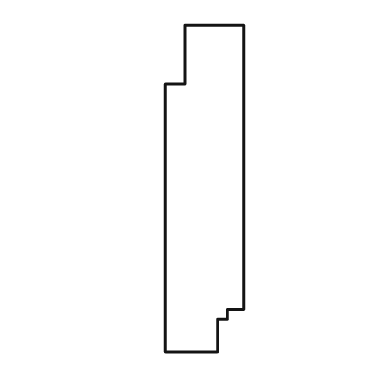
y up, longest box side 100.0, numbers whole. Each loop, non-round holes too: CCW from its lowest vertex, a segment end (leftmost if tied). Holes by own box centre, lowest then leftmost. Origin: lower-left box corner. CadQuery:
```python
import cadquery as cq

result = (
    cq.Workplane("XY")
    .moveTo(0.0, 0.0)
    .lineTo(16.0, 0.0)
    .lineTo(16.0, 10.0)
    .lineTo(19.0, 10.0)
    .lineTo(19.0, 13.0)
    .lineTo(24.0, 13.0)
    .lineTo(24.0, 100.0)
    .lineTo(6.0, 100.0)
    .lineTo(6.0, 82.0)
    .lineTo(0.0, 82.0)
    .close()
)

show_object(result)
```